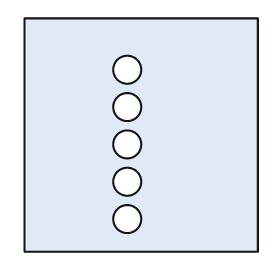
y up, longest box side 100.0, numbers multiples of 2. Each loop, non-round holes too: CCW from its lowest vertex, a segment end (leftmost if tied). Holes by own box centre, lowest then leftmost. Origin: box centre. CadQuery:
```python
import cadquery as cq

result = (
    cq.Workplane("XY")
    .moveTo(-50.0, -50.0)
    .lineTo(50.0, -50.0)
    .lineTo(50.0, 50.0)
    .lineTo(-50.0, 50.0)
    .close()
    .moveTo(-6.0, -36.0)
    .circle(6.0)
    .moveTo(-6.0, -20.0)
    .circle(6.0)
    .moveTo(-6.0, -4.0)
    .circle(6.0)
    .moveTo(-6.0, 12.0)
    .circle(6.0)
    .moveTo(-6.0, 28.0)
    .circle(6.0)
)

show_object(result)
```